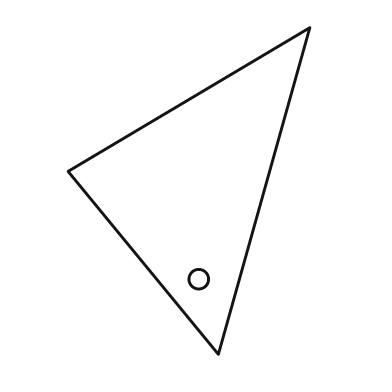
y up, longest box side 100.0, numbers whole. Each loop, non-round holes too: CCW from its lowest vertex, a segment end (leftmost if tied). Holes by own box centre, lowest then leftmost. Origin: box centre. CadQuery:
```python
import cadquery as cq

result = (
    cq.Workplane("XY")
    .moveTo(9.0, -50.0)
    .lineTo(37.0, 50.0)
    .lineTo(-37.0, 6.0)
    .close()
    .moveTo(3.0, -27.0)
    .circle(3.0)
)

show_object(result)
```